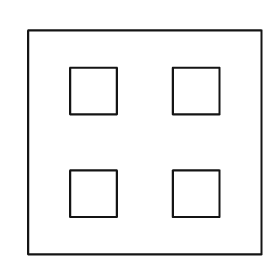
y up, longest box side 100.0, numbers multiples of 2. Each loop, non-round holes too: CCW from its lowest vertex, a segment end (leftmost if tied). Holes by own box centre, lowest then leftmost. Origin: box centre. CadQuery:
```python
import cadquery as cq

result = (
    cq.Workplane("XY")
    .moveTo(-50.0, -48.0)
    .lineTo(50.0, -48.0)
    .lineTo(50.0, 48.0)
    .lineTo(-50.0, 48.0)
    .close()
    .moveTo(-32.0, -32.0)
    .lineTo(-12.0, -32.0)
    .lineTo(-12.0, -12.0)
    .lineTo(-32.0, -12.0)
    .close()
    .moveTo(12.0, -32.0)
    .lineTo(32.0, -32.0)
    .lineTo(32.0, -12.0)
    .lineTo(12.0, -12.0)
    .close()
    .moveTo(-32.0, 12.0)
    .lineTo(-12.0, 12.0)
    .lineTo(-12.0, 32.0)
    .lineTo(-32.0, 32.0)
    .close()
    .moveTo(12.0, 12.0)
    .lineTo(32.0, 12.0)
    .lineTo(32.0, 32.0)
    .lineTo(12.0, 32.0)
    .close()
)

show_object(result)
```